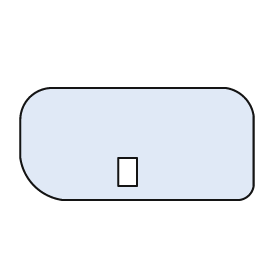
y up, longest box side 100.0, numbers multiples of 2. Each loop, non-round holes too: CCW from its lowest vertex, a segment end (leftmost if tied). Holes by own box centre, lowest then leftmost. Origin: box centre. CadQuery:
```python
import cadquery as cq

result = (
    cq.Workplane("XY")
    .moveTo(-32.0, -24.0)
    .lineTo(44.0, -24.0)
    .threePointArc((48.0, -22.0), (50.0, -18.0))
    .lineTo(50.0, 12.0)
    .threePointArc((46.0, 20.0), (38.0, 24.0))
    .lineTo(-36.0, 24.0)
    .threePointArc((-46.0, 20.0), (-50.0, 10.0))
    .lineTo(-50.0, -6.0)
    .threePointArc((-44.0, -18.0), (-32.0, -24.0))
    .close()
    .moveTo(-8.0, -18.0)
    .lineTo(0.0, -18.0)
    .lineTo(0.0, -6.0)
    .lineTo(-8.0, -6.0)
    .close()
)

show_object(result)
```